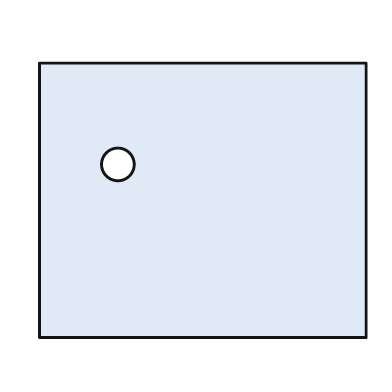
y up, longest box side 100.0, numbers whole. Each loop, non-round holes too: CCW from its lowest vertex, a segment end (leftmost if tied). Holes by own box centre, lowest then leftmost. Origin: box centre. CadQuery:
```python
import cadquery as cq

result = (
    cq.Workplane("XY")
    .moveTo(-50.0, -42.0)
    .lineTo(50.0, -42.0)
    .lineTo(50.0, 42.0)
    .lineTo(-50.0, 42.0)
    .close()
    .moveTo(-26.0, 11.0)
    .circle(5.0)
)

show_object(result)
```